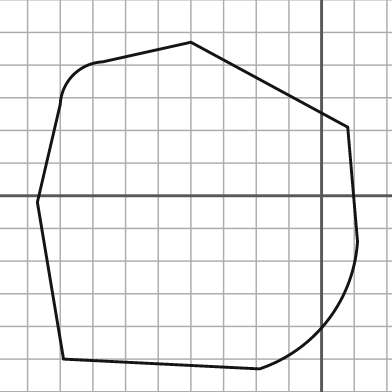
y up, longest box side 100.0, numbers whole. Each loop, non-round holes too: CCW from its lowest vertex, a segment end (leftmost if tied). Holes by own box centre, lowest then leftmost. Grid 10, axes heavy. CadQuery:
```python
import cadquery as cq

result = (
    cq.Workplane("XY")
    .moveTo(-19.0, -53.0)
    .threePointArc((2.0, -38.0), (11.0, -14.0))
    .lineTo(8.0, 21.0)
    .lineTo(-40.0, 47.0)
    .lineTo(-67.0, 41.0)
    .threePointArc((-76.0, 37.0), (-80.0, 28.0))
    .lineTo(-87.0, -2.0)
    .lineTo(-79.0, -50.0)
    .close()
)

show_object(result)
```